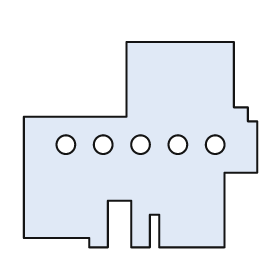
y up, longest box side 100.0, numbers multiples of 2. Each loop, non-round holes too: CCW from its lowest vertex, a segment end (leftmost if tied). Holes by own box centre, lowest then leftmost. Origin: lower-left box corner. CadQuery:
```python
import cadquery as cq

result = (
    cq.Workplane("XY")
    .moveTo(28.0, 0.0)
    .lineTo(36.0, 0.0)
    .lineTo(36.0, 20.0)
    .lineTo(46.0, 20.0)
    .lineTo(46.0, 0.0)
    .lineTo(54.0, 0.0)
    .lineTo(54.0, 14.0)
    .lineTo(58.0, 14.0)
    .lineTo(58.0, 0.0)
    .lineTo(86.0, 0.0)
    .lineTo(86.0, 32.0)
    .lineTo(100.0, 32.0)
    .lineTo(100.0, 54.0)
    .lineTo(96.0, 54.0)
    .lineTo(96.0, 60.0)
    .lineTo(90.0, 60.0)
    .lineTo(90.0, 88.0)
    .lineTo(44.0, 88.0)
    .lineTo(44.0, 56.0)
    .lineTo(0.0, 56.0)
    .lineTo(0.0, 4.0)
    .lineTo(28.0, 4.0)
    .close()
    .moveTo(18.0, 44.0)
    .circle(4.0)
    .moveTo(34.0, 44.0)
    .circle(4.0)
    .moveTo(50.0, 44.0)
    .circle(4.0)
    .moveTo(66.0, 44.0)
    .circle(4.0)
    .moveTo(82.0, 44.0)
    .circle(4.0)
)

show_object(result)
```